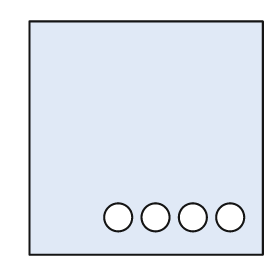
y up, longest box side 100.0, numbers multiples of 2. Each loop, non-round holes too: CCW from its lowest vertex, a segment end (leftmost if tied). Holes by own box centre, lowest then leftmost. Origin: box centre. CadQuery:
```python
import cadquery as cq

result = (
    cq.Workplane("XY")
    .moveTo(-50.0, -50.0)
    .lineTo(50.0, -50.0)
    .lineTo(50.0, 50.0)
    .lineTo(-50.0, 50.0)
    .close()
    .moveTo(-12.0, -34.0)
    .circle(6.0)
    .moveTo(4.0, -34.0)
    .circle(6.0)
    .moveTo(20.0, -34.0)
    .circle(6.0)
    .moveTo(36.0, -34.0)
    .circle(6.0)
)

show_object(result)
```